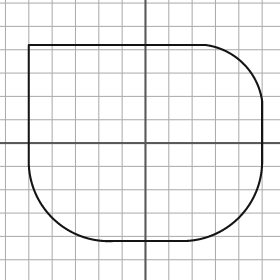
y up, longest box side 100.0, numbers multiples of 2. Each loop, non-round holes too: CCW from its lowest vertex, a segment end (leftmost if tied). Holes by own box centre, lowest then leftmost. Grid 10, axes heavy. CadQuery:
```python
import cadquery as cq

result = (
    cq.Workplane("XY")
    .moveTo(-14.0, -42.0)
    .lineTo(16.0, -42.0)
    .threePointArc((40.0, -32.0), (50.0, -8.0))
    .lineTo(50.0, 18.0)
    .threePointArc((42.0, 34.0), (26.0, 42.0))
    .lineTo(-50.0, 42.0)
    .lineTo(-50.0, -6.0)
    .threePointArc((-40.0, -32.0), (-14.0, -42.0))
    .close()
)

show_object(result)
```